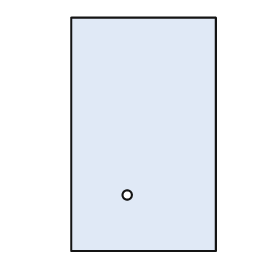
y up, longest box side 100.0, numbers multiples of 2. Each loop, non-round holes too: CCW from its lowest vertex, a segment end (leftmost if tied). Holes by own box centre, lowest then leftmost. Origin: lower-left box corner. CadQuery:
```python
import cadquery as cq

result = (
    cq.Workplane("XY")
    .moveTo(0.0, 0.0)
    .lineTo(62.0, 0.0)
    .lineTo(62.0, 100.0)
    .lineTo(0.0, 100.0)
    .close()
    .moveTo(24.0, 24.0)
    .circle(2.0)
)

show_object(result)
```